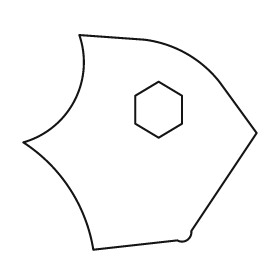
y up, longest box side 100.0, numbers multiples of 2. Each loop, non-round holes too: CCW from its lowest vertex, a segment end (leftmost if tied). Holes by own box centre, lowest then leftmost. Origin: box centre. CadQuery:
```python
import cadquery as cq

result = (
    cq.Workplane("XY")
    .moveTo(-20.0, -46.0)
    .lineTo(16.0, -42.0)
    .threePointArc((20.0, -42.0), (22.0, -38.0))
    .lineTo(50.0, 4.0)
    .lineTo(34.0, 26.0)
    .threePointArc((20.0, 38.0), (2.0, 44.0))
    .lineTo(-26.0, 46.0)
    .threePointArc((-28.0, 18.0), (-50.0, 0.0))
    .threePointArc((-30.0, -20.0), (-20.0, -46.0))
    .close()
    .moveTo(8.0, 2.0)
    .lineTo(18.0, 8.0)
    .lineTo(18.0, 20.0)
    .lineTo(8.0, 26.0)
    .lineTo(-2.0, 20.0)
    .lineTo(-2.0, 8.0)
    .close()
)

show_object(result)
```